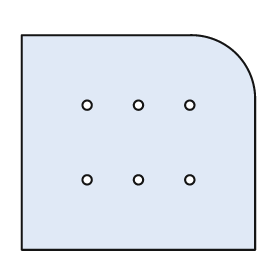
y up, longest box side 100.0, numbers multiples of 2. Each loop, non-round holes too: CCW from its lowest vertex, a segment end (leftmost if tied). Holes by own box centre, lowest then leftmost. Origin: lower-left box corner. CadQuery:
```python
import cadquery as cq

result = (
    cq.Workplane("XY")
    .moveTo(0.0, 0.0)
    .lineTo(100.0, 0.0)
    .lineTo(100.0, 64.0)
    .threePointArc((92.0, 84.0), (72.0, 92.0))
    .lineTo(0.0, 92.0)
    .close()
    .moveTo(28.0, 30.0)
    .circle(2.0)
    .moveTo(50.0, 30.0)
    .circle(2.0)
    .moveTo(72.0, 30.0)
    .circle(2.0)
    .moveTo(28.0, 62.0)
    .circle(2.0)
    .moveTo(50.0, 62.0)
    .circle(2.0)
    .moveTo(72.0, 62.0)
    .circle(2.0)
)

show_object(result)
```